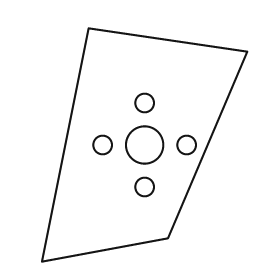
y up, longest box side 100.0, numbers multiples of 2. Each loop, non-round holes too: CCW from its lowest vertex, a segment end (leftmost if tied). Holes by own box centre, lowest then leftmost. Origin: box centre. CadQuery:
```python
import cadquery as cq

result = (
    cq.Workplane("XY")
    .moveTo(-44.0, -50.0)
    .lineTo(10.0, -40.0)
    .lineTo(44.0, 40.0)
    .lineTo(-24.0, 50.0)
    .close()
    .moveTo(0.0, -18.0)
    .circle(4.0)
    .moveTo(-18.0, 0.0)
    .circle(4.0)
    .moveTo(0.0, 0.0)
    .circle(8.0)
    .moveTo(18.0, 0.0)
    .circle(4.0)
    .moveTo(0.0, 18.0)
    .circle(4.0)
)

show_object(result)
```